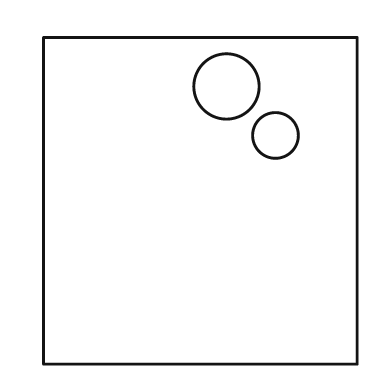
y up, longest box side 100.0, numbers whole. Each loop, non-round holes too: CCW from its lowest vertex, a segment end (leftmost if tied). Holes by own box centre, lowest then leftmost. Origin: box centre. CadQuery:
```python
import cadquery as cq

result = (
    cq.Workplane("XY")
    .moveTo(-48.0, -50.0)
    .lineTo(48.0, -50.0)
    .lineTo(48.0, 50.0)
    .lineTo(-48.0, 50.0)
    .close()
    .moveTo(23.0, 20.0)
    .circle(7.0)
    .moveTo(8.0, 35.0)
    .circle(10.0)
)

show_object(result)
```